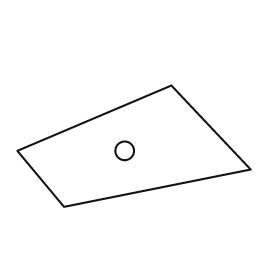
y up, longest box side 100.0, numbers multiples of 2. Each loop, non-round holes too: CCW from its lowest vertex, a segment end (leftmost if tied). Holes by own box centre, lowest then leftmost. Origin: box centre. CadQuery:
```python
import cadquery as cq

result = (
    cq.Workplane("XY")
    .moveTo(-30.0, -26.0)
    .lineTo(50.0, -10.0)
    .lineTo(16.0, 26.0)
    .lineTo(-50.0, -2.0)
    .close()
    .moveTo(-4.0, -2.0)
    .circle(4.0)
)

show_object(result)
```